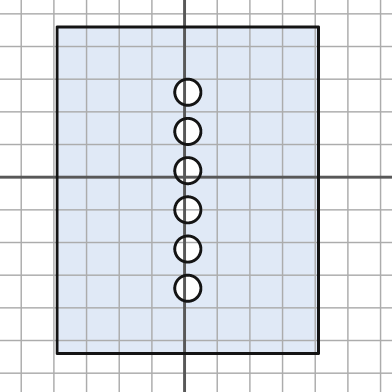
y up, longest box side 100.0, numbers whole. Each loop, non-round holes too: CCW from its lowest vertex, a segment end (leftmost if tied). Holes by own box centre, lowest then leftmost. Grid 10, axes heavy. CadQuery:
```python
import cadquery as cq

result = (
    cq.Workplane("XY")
    .moveTo(-39.0, -54.0)
    .lineTo(41.0, -54.0)
    .lineTo(41.0, 46.0)
    .lineTo(-39.0, 46.0)
    .close()
    .moveTo(1.0, -34.0)
    .circle(4.0)
    .moveTo(1.0, -22.0)
    .circle(4.0)
    .moveTo(1.0, -10.0)
    .circle(4.0)
    .moveTo(1.0, 2.0)
    .circle(4.0)
    .moveTo(1.0, 14.0)
    .circle(4.0)
    .moveTo(1.0, 26.0)
    .circle(4.0)
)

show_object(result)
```